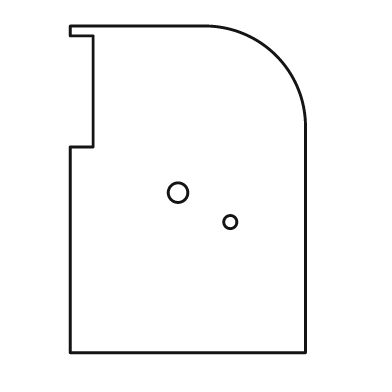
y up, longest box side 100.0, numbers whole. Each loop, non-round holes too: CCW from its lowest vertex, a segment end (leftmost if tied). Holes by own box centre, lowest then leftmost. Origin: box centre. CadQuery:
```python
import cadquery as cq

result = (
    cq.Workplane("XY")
    .moveTo(-36.0, -50.0)
    .lineTo(36.0, -50.0)
    .lineTo(36.0, 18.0)
    .threePointArc((27.0, 41.0), (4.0, 50.0))
    .lineTo(-36.0, 50.0)
    .lineTo(-36.0, 47.0)
    .lineTo(-29.0, 47.0)
    .lineTo(-29.0, 13.0)
    .lineTo(-36.0, 13.0)
    .close()
    .moveTo(13.0, -10.0)
    .circle(2.0)
    .moveTo(-3.0, -1.0)
    .circle(3.0)
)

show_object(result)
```